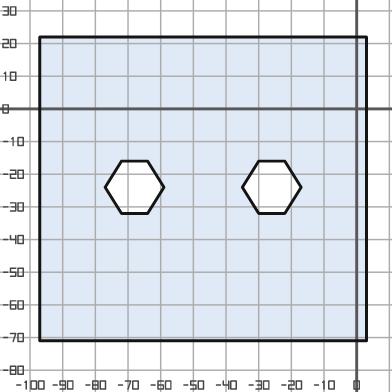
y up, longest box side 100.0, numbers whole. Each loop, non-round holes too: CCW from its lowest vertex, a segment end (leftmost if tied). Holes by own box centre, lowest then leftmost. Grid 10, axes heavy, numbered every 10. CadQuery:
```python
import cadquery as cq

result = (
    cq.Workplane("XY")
    .moveTo(-97.0, -71.0)
    .lineTo(3.0, -71.0)
    .lineTo(3.0, 22.0)
    .lineTo(-97.0, 22.0)
    .close()
    .moveTo(-72.0, -32.0)
    .lineTo(-64.0, -32.0)
    .lineTo(-59.0, -24.0)
    .lineTo(-64.0, -16.0)
    .lineTo(-72.0, -16.0)
    .lineTo(-77.0, -24.0)
    .close()
    .moveTo(-30.0, -32.0)
    .lineTo(-22.0, -32.0)
    .lineTo(-17.0, -24.0)
    .lineTo(-22.0, -16.0)
    .lineTo(-30.0, -16.0)
    .lineTo(-35.0, -24.0)
    .close()
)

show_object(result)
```